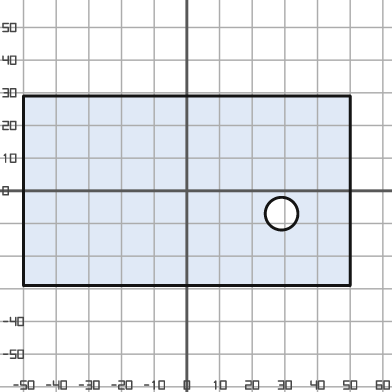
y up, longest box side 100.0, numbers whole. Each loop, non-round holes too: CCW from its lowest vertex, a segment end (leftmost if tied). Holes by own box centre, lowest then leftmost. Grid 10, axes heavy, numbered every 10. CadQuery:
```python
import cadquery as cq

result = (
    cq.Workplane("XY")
    .moveTo(-50.0, -29.0)
    .lineTo(50.0, -29.0)
    .lineTo(50.0, 29.0)
    .lineTo(-50.0, 29.0)
    .close()
    .moveTo(29.0, -7.0)
    .circle(5.0)
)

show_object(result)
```